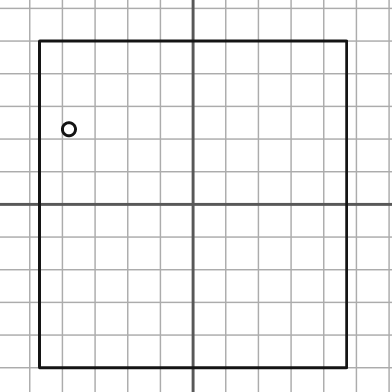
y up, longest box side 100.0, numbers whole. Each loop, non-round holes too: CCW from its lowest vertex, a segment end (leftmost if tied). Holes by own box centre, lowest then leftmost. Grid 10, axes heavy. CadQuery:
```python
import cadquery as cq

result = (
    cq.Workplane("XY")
    .moveTo(-47.0, -50.0)
    .lineTo(47.0, -50.0)
    .lineTo(47.0, 50.0)
    .lineTo(-47.0, 50.0)
    .close()
    .moveTo(-38.0, 23.0)
    .circle(2.0)
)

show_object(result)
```